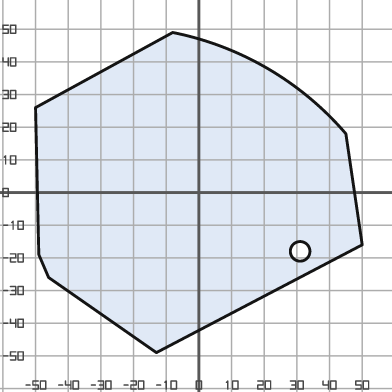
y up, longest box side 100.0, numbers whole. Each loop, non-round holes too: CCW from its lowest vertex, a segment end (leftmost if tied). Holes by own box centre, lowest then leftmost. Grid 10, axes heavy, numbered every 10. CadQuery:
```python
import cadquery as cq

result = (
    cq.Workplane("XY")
    .moveTo(-13.0, -49.0)
    .lineTo(50.0, -16.0)
    .lineTo(45.0, 18.0)
    .threePointArc((21.0, 38.0), (-8.0, 49.0))
    .lineTo(-50.0, 26.0)
    .lineTo(-49.0, -19.0)
    .lineTo(-46.0, -26.0)
    .close()
    .moveTo(31.0, -18.0)
    .circle(3.0)
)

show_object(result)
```